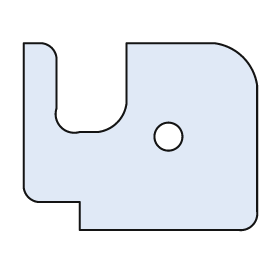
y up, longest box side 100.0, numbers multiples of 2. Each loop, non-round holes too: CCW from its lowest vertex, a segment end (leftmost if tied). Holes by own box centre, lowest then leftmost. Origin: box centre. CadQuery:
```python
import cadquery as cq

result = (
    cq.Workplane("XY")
    .moveTo(-26.0, -40.0)
    .lineTo(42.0, -40.0)
    .threePointArc((48.0, -38.0), (50.0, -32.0))
    .lineTo(50.0, 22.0)
    .threePointArc((44.0, 34.0), (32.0, 40.0))
    .lineTo(-6.0, 40.0)
    .lineTo(-6.0, 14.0)
    .threePointArc((-10.0, 6.0), (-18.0, 2.0))
    .lineTo(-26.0, 2.0)
    .threePointArc((-34.0, 4.0), (-36.0, 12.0))
    .lineTo(-36.0, 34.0)
    .threePointArc((-38.0, 38.0), (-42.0, 40.0))
    .lineTo(-50.0, 40.0)
    .lineTo(-50.0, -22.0)
    .threePointArc((-48.0, -26.0), (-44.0, -28.0))
    .lineTo(-26.0, -28.0)
    .close()
    .moveTo(12.0, 0.0)
    .circle(6.0)
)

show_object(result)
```